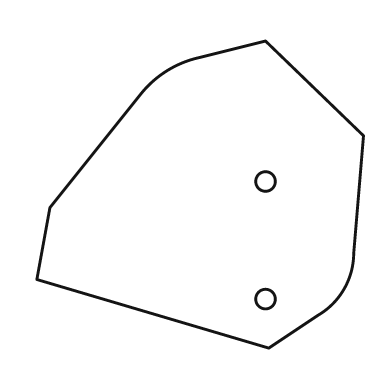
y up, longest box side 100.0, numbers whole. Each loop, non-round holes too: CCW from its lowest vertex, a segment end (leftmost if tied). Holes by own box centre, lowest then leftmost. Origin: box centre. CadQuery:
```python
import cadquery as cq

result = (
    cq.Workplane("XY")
    .moveTo(21.0, -47.0)
    .lineTo(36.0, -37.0)
    .threePointArc((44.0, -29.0), (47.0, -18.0))
    .lineTo(50.0, 18.0)
    .lineTo(20.0, 47.0)
    .lineTo(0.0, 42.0)
    .threePointArc((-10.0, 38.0), (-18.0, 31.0))
    .lineTo(-46.0, -4.0)
    .lineTo(-50.0, -26.0)
    .close()
    .moveTo(20.0, -32.0)
    .circle(3.0)
    .moveTo(20.0, 4.0)
    .circle(3.0)
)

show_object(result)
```